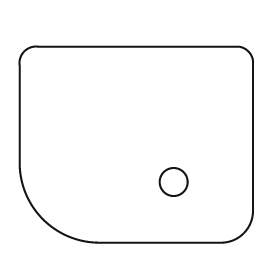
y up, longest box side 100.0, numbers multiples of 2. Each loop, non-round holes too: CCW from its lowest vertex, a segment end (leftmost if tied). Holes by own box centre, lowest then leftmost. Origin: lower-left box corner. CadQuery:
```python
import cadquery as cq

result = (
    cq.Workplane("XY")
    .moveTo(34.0, 0.0)
    .lineTo(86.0, 0.0)
    .threePointArc((96.0, 4.0), (100.0, 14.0))
    .lineTo(100.0, 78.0)
    .threePointArc((98.0, 82.0), (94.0, 84.0))
    .lineTo(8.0, 84.0)
    .threePointArc((2.0, 82.0), (0.0, 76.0))
    .lineTo(0.0, 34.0)
    .threePointArc((10.0, 10.0), (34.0, 0.0))
    .close()
    .moveTo(66.0, 26.0)
    .circle(6.0)
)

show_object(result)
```